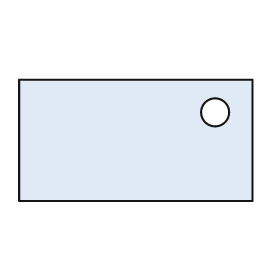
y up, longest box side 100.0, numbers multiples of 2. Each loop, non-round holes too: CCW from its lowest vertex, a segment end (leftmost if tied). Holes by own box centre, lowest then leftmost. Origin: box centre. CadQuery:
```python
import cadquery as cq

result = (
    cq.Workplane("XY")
    .moveTo(-50.0, -26.0)
    .lineTo(50.0, -26.0)
    .lineTo(50.0, 26.0)
    .lineTo(-50.0, 26.0)
    .close()
    .moveTo(34.0, 12.0)
    .circle(6.0)
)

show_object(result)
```